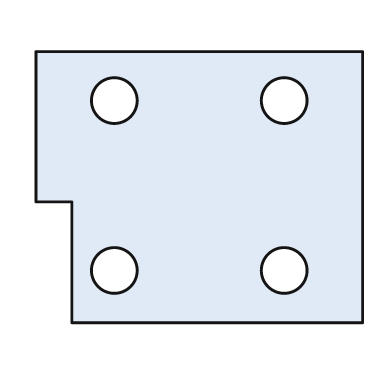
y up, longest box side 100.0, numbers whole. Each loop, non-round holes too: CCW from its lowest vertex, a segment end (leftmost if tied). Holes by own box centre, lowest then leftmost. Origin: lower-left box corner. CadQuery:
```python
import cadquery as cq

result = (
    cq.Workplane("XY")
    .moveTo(11.0, 0.0)
    .lineTo(100.0, 0.0)
    .lineTo(100.0, 83.0)
    .lineTo(0.0, 83.0)
    .lineTo(0.0, 37.0)
    .lineTo(11.0, 37.0)
    .close()
    .moveTo(24.0, 16.0)
    .circle(7.0)
    .moveTo(76.0, 16.0)
    .circle(7.0)
    .moveTo(24.0, 68.0)
    .circle(7.0)
    .moveTo(76.0, 68.0)
    .circle(7.0)
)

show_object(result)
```